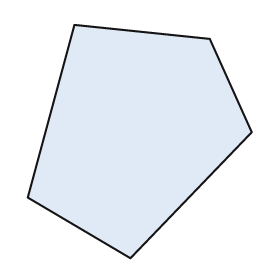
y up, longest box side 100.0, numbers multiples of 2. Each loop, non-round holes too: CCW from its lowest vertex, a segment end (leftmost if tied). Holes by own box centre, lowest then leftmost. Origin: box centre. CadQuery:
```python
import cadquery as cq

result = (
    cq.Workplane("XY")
    .moveTo(-4.0, -50.0)
    .lineTo(48.0, 4.0)
    .lineTo(30.0, 44.0)
    .lineTo(-28.0, 50.0)
    .lineTo(-48.0, -24.0)
    .close()
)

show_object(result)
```